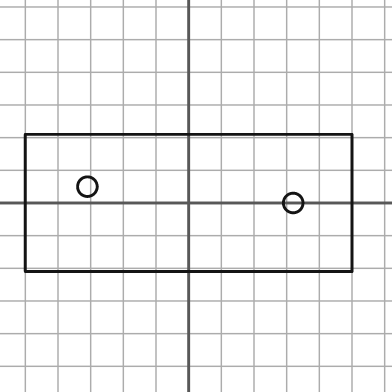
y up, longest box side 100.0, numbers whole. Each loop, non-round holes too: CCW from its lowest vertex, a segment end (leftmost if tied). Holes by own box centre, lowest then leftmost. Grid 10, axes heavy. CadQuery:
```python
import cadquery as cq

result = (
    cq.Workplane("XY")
    .moveTo(-50.0, -21.0)
    .lineTo(50.0, -21.0)
    .lineTo(50.0, 21.0)
    .lineTo(-50.0, 21.0)
    .close()
    .moveTo(32.0, 0.0)
    .circle(3.0)
    .moveTo(-31.0, 5.0)
    .circle(3.0)
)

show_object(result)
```